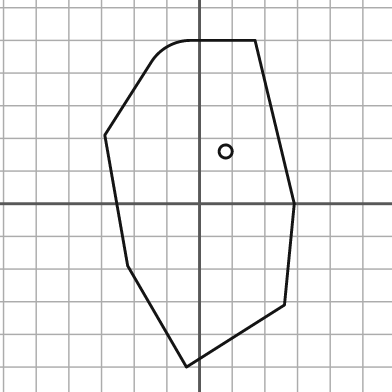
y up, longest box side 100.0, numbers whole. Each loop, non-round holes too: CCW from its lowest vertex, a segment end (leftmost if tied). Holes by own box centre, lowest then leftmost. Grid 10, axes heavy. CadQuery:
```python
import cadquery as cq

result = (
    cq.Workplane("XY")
    .moveTo(-4.0, -50.0)
    .lineTo(26.0, -31.0)
    .lineTo(29.0, 0.0)
    .lineTo(17.0, 50.0)
    .lineTo(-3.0, 50.0)
    .threePointArc((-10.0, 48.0), (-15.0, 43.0))
    .lineTo(-29.0, 21.0)
    .lineTo(-22.0, -19.0)
    .close()
    .moveTo(8.0, 16.0)
    .circle(2.0)
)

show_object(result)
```